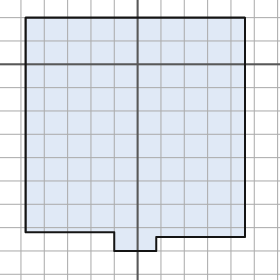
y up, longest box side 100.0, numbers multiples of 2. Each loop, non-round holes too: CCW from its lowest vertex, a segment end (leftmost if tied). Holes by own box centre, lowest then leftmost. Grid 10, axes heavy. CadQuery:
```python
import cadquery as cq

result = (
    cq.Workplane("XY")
    .moveTo(-10.0, -80.0)
    .lineTo(8.0, -80.0)
    .lineTo(8.0, -74.0)
    .lineTo(46.0, -74.0)
    .lineTo(46.0, 20.0)
    .lineTo(-48.0, 20.0)
    .lineTo(-48.0, -72.0)
    .lineTo(-10.0, -72.0)
    .close()
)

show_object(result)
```